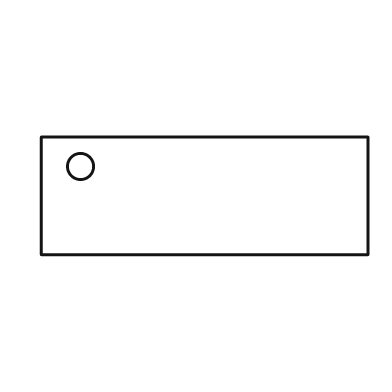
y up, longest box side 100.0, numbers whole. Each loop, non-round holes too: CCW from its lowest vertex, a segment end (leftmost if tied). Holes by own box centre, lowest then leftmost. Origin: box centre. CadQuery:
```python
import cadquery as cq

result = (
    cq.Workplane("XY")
    .moveTo(-50.0, -18.0)
    .lineTo(50.0, -18.0)
    .lineTo(50.0, 18.0)
    .lineTo(-50.0, 18.0)
    .close()
    .moveTo(-38.0, 9.0)
    .circle(4.0)
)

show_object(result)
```